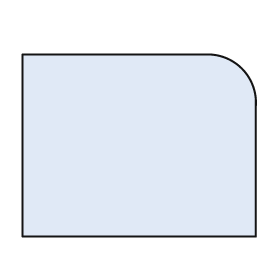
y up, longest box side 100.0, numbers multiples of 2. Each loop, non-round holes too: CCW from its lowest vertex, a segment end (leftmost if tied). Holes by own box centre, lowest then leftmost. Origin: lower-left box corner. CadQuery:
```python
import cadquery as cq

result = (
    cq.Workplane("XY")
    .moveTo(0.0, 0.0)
    .lineTo(100.0, 0.0)
    .lineTo(100.0, 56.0)
    .threePointArc((94.0, 72.0), (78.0, 78.0))
    .lineTo(0.0, 78.0)
    .close()
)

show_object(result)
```